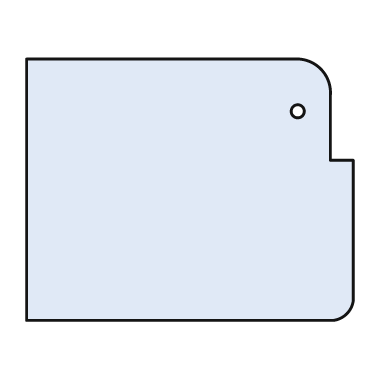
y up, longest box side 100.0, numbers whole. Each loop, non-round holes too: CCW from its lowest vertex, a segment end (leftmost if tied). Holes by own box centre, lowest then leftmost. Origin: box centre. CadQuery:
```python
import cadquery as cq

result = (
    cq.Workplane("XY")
    .moveTo(-50.0, -40.0)
    .lineTo(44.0, -40.0)
    .threePointArc((48.0, -38.0), (50.0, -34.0))
    .lineTo(50.0, 9.0)
    .lineTo(43.0, 9.0)
    .lineTo(43.0, 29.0)
    .threePointArc((40.0, 37.0), (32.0, 40.0))
    .lineTo(-50.0, 40.0)
    .close()
    .moveTo(33.0, 24.0)
    .circle(2.0)
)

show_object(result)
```